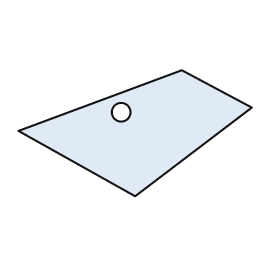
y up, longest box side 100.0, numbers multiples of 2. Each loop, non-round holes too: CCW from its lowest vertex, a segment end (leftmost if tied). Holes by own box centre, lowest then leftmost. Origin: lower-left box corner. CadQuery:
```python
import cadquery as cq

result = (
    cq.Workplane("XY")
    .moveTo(50.0, 0.0)
    .lineTo(100.0, 38.0)
    .lineTo(70.0, 54.0)
    .lineTo(0.0, 28.0)
    .close()
    .moveTo(44.0, 36.0)
    .circle(4.0)
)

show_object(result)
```